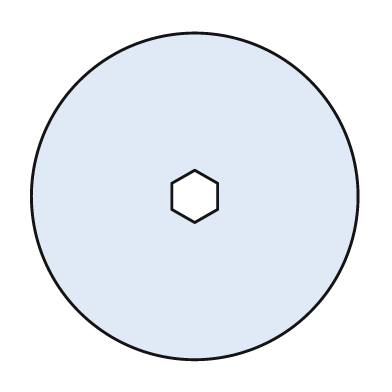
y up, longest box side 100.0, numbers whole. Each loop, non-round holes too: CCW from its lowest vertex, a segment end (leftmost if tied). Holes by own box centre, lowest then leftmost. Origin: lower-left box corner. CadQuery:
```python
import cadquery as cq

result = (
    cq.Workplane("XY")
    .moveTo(50.0, 50.0)
    .circle(50.0)
    .moveTo(50.0, 42.0)
    .lineTo(57.0, 46.0)
    .lineTo(57.0, 54.0)
    .lineTo(50.0, 58.0)
    .lineTo(43.0, 54.0)
    .lineTo(43.0, 46.0)
    .close()
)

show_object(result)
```